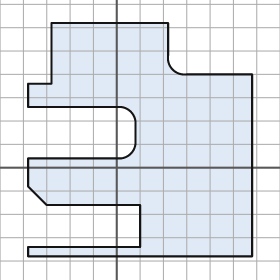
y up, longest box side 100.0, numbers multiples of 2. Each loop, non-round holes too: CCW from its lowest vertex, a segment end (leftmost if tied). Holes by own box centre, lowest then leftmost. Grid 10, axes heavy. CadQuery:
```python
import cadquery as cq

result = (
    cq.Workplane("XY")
    .moveTo(-38.0, -38.0)
    .lineTo(58.0, -38.0)
    .lineTo(58.0, 40.0)
    .lineTo(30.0, 40.0)
    .threePointArc((24.0, 42.0), (22.0, 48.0))
    .lineTo(22.0, 62.0)
    .lineTo(-28.0, 62.0)
    .lineTo(-28.0, 36.0)
    .lineTo(-38.0, 36.0)
    .lineTo(-38.0, 26.0)
    .lineTo(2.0, 26.0)
    .threePointArc((6.0, 24.0), (8.0, 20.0))
    .lineTo(8.0, 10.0)
    .threePointArc((6.0, 6.0), (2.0, 4.0))
    .lineTo(-38.0, 4.0)
    .lineTo(-38.0, -8.0)
    .lineTo(-30.0, -16.0)
    .lineTo(10.0, -16.0)
    .lineTo(10.0, -34.0)
    .lineTo(-38.0, -34.0)
    .close()
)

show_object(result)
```